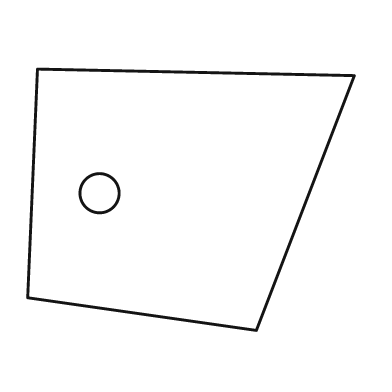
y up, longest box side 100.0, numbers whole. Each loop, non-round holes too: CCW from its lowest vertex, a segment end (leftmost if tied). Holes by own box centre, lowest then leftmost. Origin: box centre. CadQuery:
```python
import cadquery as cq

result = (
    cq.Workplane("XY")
    .moveTo(20.0, -40.0)
    .lineTo(50.0, 38.0)
    .lineTo(-47.0, 40.0)
    .lineTo(-50.0, -30.0)
    .close()
    .moveTo(-28.0, 2.0)
    .circle(6.0)
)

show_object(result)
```